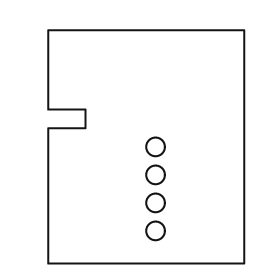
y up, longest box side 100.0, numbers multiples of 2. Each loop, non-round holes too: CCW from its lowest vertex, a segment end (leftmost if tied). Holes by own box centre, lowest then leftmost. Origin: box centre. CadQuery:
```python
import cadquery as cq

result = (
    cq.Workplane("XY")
    .moveTo(-42.0, -50.0)
    .lineTo(42.0, -50.0)
    .lineTo(42.0, 50.0)
    .lineTo(-42.0, 50.0)
    .lineTo(-42.0, 16.0)
    .lineTo(-26.0, 16.0)
    .lineTo(-26.0, 8.0)
    .lineTo(-42.0, 8.0)
    .close()
    .moveTo(4.0, -36.0)
    .circle(4.0)
    .moveTo(4.0, -24.0)
    .circle(4.0)
    .moveTo(4.0, -12.0)
    .circle(4.0)
    .moveTo(4.0, 0.0)
    .circle(4.0)
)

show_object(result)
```